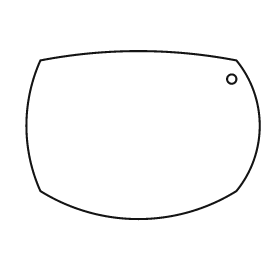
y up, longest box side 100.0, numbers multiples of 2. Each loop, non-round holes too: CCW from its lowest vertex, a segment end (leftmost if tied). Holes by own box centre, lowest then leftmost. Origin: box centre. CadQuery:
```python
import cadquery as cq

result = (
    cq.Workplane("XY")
    .moveTo(-44.0, -24.0)
    .threePointArc((-2.0, -36.0), (40.0, -24.0))
    .threePointArc((50.0, 4.0), (40.0, 32.0))
    .threePointArc((-2.0, 36.0), (-44.0, 32.0))
    .threePointArc((-50.0, 4.0), (-44.0, -24.0))
    .close()
    .moveTo(38.0, 24.0)
    .circle(2.0)
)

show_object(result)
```